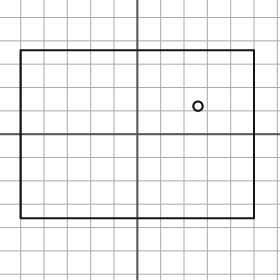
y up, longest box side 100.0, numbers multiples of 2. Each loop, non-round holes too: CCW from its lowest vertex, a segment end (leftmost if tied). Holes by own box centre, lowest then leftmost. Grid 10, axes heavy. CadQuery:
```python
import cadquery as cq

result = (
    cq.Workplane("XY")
    .moveTo(-50.0, -36.0)
    .lineTo(50.0, -36.0)
    .lineTo(50.0, 36.0)
    .lineTo(-50.0, 36.0)
    .close()
    .moveTo(26.0, 12.0)
    .circle(2.0)
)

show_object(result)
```